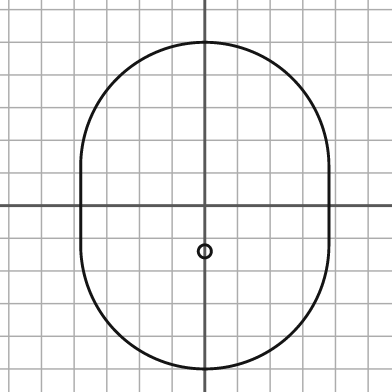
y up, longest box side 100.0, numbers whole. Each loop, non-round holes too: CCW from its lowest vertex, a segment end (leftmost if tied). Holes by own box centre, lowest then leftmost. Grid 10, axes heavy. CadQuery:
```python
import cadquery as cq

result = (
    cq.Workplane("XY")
    .moveTo(-38.0, -12.0)
    .threePointArc((0.0, -50.0), (38.0, -12.0))
    .lineTo(38.0, 12.0)
    .threePointArc((0.0, 50.0), (-38.0, 12.0))
    .close()
    .moveTo(0.0, -14.0)
    .circle(2.0)
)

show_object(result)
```